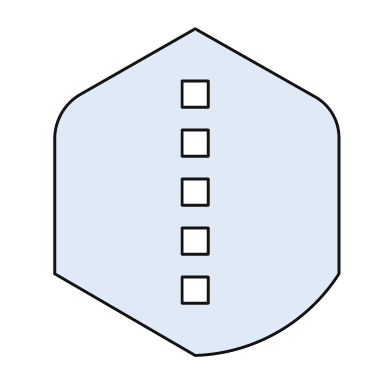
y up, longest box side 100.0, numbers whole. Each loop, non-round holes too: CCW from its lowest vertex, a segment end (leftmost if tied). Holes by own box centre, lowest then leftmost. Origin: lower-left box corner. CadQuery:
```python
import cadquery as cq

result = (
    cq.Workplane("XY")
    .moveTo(43.0, 0.0)
    .threePointArc((68.0, 7.0), (87.0, 25.0))
    .lineTo(87.0, 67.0)
    .threePointArc((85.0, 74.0), (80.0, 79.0))
    .lineTo(43.0, 100.0)
    .lineTo(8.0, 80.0)
    .threePointArc((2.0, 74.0), (0.0, 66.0))
    .lineTo(0.0, 25.0)
    .close()
    .moveTo(39.0, 16.0)
    .lineTo(47.0, 16.0)
    .lineTo(47.0, 24.0)
    .lineTo(39.0, 24.0)
    .close()
    .moveTo(39.0, 31.0)
    .lineTo(47.0, 31.0)
    .lineTo(47.0, 39.0)
    .lineTo(39.0, 39.0)
    .close()
    .moveTo(39.0, 46.0)
    .lineTo(47.0, 46.0)
    .lineTo(47.0, 54.0)
    .lineTo(39.0, 54.0)
    .close()
    .moveTo(39.0, 61.0)
    .lineTo(47.0, 61.0)
    .lineTo(47.0, 69.0)
    .lineTo(39.0, 69.0)
    .close()
    .moveTo(39.0, 76.0)
    .lineTo(47.0, 76.0)
    .lineTo(47.0, 84.0)
    .lineTo(39.0, 84.0)
    .close()
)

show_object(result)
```